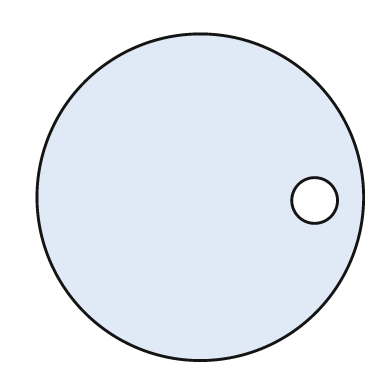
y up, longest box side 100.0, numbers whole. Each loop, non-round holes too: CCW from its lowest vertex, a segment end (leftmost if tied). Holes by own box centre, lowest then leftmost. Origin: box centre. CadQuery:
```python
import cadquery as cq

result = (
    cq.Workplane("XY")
    .moveTo(0.0, 0.0)
    .circle(50.0)
    .moveTo(35.0, -1.0)
    .circle(7.0)
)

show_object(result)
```